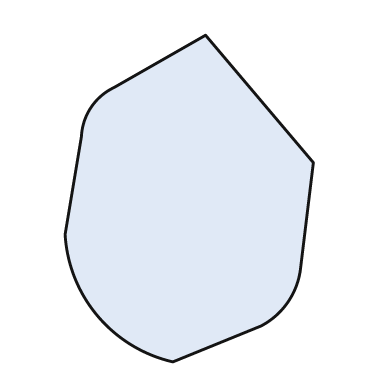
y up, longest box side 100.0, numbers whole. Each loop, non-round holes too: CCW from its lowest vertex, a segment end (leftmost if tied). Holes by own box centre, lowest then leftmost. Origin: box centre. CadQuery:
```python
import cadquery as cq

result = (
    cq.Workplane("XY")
    .moveTo(-5.0, -50.0)
    .lineTo(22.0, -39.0)
    .threePointArc((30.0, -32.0), (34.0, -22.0))
    .lineTo(38.0, 11.0)
    .lineTo(5.0, 50.0)
    .lineTo(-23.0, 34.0)
    .threePointArc((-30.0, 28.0), (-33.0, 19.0))
    .lineTo(-38.0, -11.0)
    .threePointArc((-28.0, -36.0), (-5.0, -50.0))
    .close()
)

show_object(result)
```